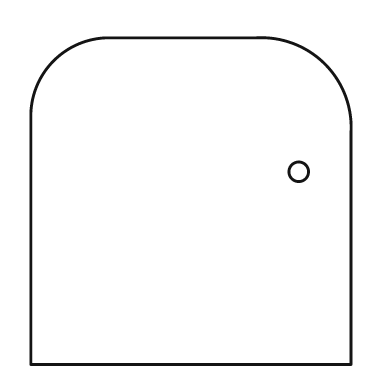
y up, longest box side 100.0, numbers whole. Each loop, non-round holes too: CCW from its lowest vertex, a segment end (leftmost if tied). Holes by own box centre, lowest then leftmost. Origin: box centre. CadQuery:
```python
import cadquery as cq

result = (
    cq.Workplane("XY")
    .moveTo(-49.0, -50.0)
    .lineTo(49.0, -50.0)
    .lineTo(49.0, 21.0)
    .threePointArc((41.0, 42.0), (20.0, 50.0))
    .lineTo(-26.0, 50.0)
    .threePointArc((-42.0, 43.0), (-49.0, 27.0))
    .close()
    .moveTo(33.0, 9.0)
    .circle(3.0)
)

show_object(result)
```